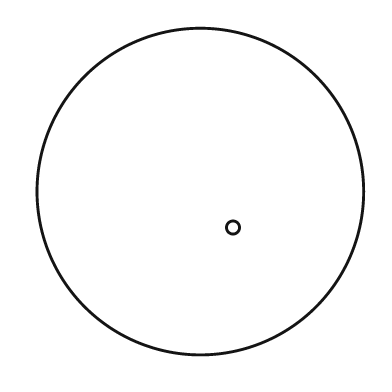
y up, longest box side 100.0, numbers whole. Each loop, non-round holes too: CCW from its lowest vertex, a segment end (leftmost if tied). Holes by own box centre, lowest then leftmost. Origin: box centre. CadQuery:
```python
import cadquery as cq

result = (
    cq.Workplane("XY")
    .moveTo(0.0, 0.0)
    .circle(50.0)
    .moveTo(10.0, -11.0)
    .circle(2.0)
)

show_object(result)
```